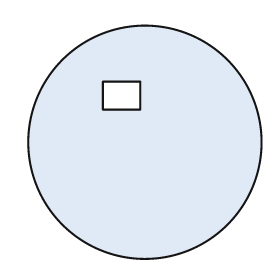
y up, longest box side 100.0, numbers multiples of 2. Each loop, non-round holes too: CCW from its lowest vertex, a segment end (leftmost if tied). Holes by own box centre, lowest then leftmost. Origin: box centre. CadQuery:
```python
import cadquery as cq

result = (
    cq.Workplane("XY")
    .moveTo(0.0, 0.0)
    .circle(50.0)
    .moveTo(-18.0, 14.0)
    .lineTo(-2.0, 14.0)
    .lineTo(-2.0, 26.0)
    .lineTo(-18.0, 26.0)
    .close()
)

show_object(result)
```